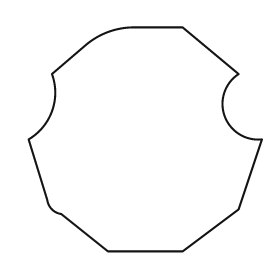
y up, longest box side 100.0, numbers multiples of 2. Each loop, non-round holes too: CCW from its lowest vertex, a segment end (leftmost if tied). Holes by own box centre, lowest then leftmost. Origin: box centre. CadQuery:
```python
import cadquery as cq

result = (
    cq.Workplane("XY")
    .moveTo(-16.0, -48.0)
    .lineTo(16.0, -48.0)
    .lineTo(40.0, -30.0)
    .lineTo(50.0, 0.0)
    .threePointArc((34.0, 10.0), (40.0, 28.0))
    .lineTo(16.0, 48.0)
    .lineTo(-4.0, 48.0)
    .threePointArc((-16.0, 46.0), (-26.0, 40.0))
    .lineTo(-40.0, 28.0)
    .threePointArc((-40.0, 12.0), (-50.0, 0.0))
    .lineTo(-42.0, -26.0)
    .threePointArc((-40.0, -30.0), (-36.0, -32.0))
    .close()
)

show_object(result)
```